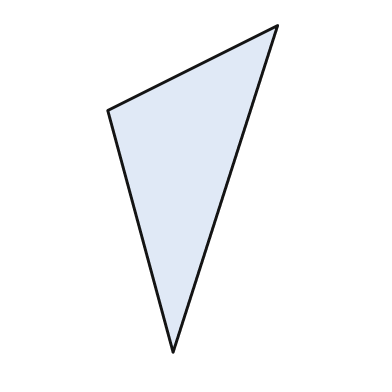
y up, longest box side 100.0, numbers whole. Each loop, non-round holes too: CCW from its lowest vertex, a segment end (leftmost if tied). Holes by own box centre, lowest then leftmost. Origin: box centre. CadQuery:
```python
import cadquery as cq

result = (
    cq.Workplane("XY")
    .moveTo(-6.0, -50.0)
    .lineTo(26.0, 50.0)
    .lineTo(-26.0, 24.0)
    .close()
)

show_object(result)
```